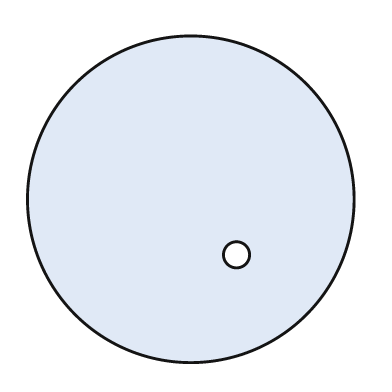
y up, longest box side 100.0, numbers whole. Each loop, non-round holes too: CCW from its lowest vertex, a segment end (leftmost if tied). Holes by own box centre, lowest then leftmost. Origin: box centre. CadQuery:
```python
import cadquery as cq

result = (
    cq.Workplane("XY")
    .moveTo(0.0, 0.0)
    .circle(50.0)
    .moveTo(14.0, -17.0)
    .circle(4.0)
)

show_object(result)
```